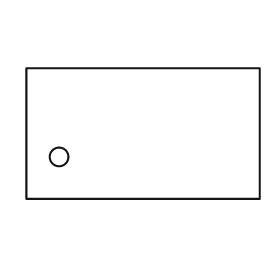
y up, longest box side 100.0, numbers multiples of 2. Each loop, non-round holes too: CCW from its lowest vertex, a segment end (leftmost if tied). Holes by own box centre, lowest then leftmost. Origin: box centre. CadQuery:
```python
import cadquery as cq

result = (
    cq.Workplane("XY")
    .moveTo(-50.0, -28.0)
    .lineTo(50.0, -28.0)
    .lineTo(50.0, 28.0)
    .lineTo(-50.0, 28.0)
    .close()
    .moveTo(-36.0, -10.0)
    .circle(4.0)
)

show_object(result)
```